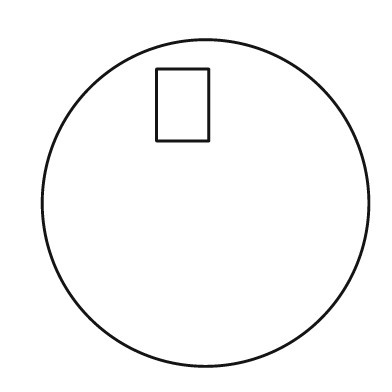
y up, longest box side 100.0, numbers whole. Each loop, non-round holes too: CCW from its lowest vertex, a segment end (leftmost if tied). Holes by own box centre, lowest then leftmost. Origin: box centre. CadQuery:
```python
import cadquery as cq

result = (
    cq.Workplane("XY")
    .moveTo(0.0, 0.0)
    .circle(50.0)
    .moveTo(-15.0, 19.0)
    .lineTo(1.0, 19.0)
    .lineTo(1.0, 41.0)
    .lineTo(-15.0, 41.0)
    .close()
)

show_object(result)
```